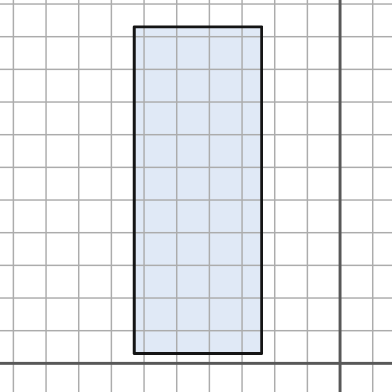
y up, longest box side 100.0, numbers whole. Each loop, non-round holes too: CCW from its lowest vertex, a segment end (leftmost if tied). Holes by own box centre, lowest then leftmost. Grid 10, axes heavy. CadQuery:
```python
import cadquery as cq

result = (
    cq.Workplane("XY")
    .moveTo(-63.0, 3.0)
    .lineTo(-24.0, 3.0)
    .lineTo(-24.0, 103.0)
    .lineTo(-63.0, 103.0)
    .close()
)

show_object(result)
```